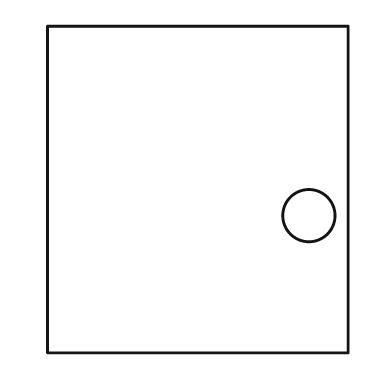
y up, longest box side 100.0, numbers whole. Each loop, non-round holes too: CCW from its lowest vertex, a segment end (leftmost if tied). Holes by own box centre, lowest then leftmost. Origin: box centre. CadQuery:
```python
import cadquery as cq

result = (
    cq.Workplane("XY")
    .moveTo(-46.0, -50.0)
    .lineTo(46.0, -50.0)
    .lineTo(46.0, 50.0)
    .lineTo(-46.0, 50.0)
    .close()
    .moveTo(34.0, -8.0)
    .circle(8.0)
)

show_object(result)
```